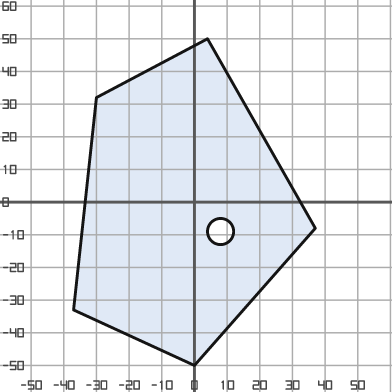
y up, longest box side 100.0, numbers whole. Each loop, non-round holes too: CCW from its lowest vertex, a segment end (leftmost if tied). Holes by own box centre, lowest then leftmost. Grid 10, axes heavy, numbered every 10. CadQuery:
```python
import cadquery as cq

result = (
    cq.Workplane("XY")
    .moveTo(0.0, -50.0)
    .lineTo(37.0, -8.0)
    .lineTo(4.0, 50.0)
    .lineTo(-30.0, 32.0)
    .lineTo(-37.0, -33.0)
    .close()
    .moveTo(8.0, -9.0)
    .circle(4.0)
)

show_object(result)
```